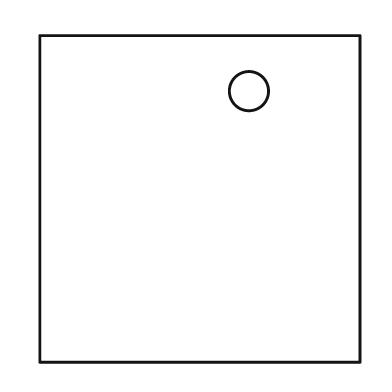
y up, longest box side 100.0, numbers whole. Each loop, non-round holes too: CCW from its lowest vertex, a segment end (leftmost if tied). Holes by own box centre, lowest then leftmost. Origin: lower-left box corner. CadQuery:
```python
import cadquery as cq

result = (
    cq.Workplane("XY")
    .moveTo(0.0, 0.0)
    .lineTo(98.0, 0.0)
    .lineTo(98.0, 100.0)
    .lineTo(0.0, 100.0)
    .close()
    .moveTo(64.0, 83.0)
    .circle(6.0)
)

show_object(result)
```